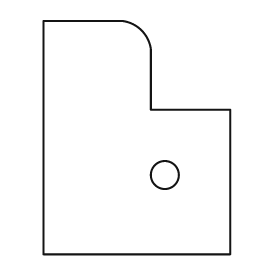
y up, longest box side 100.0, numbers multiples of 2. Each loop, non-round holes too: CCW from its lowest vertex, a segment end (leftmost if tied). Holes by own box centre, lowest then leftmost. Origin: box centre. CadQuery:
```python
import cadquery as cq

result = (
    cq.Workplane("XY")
    .moveTo(-40.0, -50.0)
    .lineTo(40.0, -50.0)
    .lineTo(40.0, 12.0)
    .lineTo(6.0, 12.0)
    .lineTo(6.0, 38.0)
    .threePointArc((2.0, 46.0), (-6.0, 50.0))
    .lineTo(-40.0, 50.0)
    .close()
    .moveTo(12.0, -16.0)
    .circle(6.0)
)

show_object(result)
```